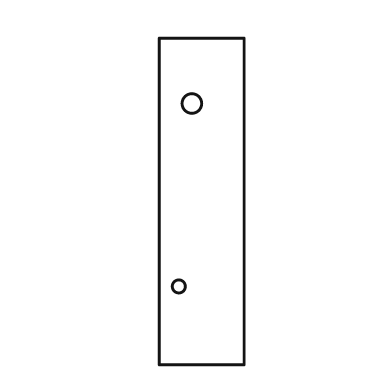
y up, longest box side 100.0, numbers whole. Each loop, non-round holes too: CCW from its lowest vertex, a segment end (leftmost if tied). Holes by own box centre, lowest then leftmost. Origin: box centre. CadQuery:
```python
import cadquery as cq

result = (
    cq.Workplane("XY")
    .moveTo(-13.0, -50.0)
    .lineTo(13.0, -50.0)
    .lineTo(13.0, 50.0)
    .lineTo(-13.0, 50.0)
    .close()
    .moveTo(-7.0, -26.0)
    .circle(2.0)
    .moveTo(-3.0, 30.0)
    .circle(3.0)
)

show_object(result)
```